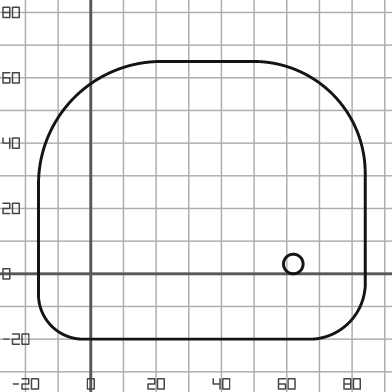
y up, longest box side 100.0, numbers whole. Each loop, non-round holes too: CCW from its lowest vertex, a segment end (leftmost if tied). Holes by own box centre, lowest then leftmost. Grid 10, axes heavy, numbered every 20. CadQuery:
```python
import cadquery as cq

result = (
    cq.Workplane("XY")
    .moveTo(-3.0, -20.0)
    .lineTo(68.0, -20.0)
    .threePointArc((79.0, -15.0), (84.0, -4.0))
    .lineTo(84.0, 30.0)
    .threePointArc((74.0, 55.0), (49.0, 65.0))
    .lineTo(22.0, 65.0)
    .threePointArc((-5.0, 54.0), (-16.0, 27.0))
    .lineTo(-16.0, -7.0)
    .threePointArc((-12.0, -16.0), (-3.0, -20.0))
    .close()
    .moveTo(62.0, 3.0)
    .circle(3.0)
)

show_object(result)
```